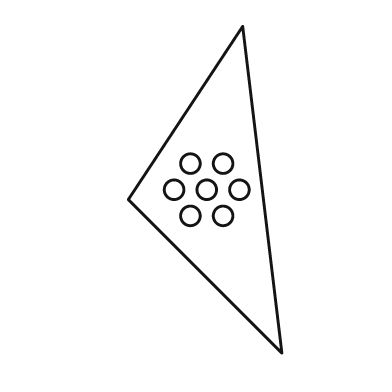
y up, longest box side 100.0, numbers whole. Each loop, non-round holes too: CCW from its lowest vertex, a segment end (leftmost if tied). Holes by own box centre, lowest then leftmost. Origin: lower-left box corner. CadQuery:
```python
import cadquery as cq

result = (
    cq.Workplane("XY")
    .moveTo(47.0, 0.0)
    .lineTo(35.0, 100.0)
    .lineTo(0.0, 47.0)
    .close()
    .moveTo(19.0, 42.0)
    .circle(3.0)
    .moveTo(29.0, 42.0)
    .circle(3.0)
    .moveTo(14.0, 50.0)
    .circle(3.0)
    .moveTo(24.0, 50.0)
    .circle(3.0)
    .moveTo(34.0, 50.0)
    .circle(3.0)
    .moveTo(19.0, 58.0)
    .circle(3.0)
    .moveTo(29.0, 58.0)
    .circle(3.0)
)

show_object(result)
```